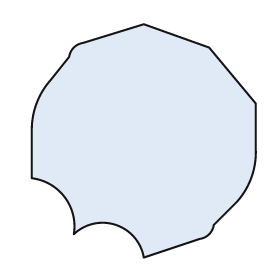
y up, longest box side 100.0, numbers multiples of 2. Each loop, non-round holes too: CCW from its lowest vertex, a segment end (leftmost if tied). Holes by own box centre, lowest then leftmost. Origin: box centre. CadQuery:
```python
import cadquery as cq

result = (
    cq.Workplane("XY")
    .moveTo(0.0, -50.0)
    .lineTo(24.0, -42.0)
    .threePointArc((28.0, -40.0), (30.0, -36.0))
    .lineTo(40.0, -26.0)
    .threePointArc((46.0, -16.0), (48.0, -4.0))
    .lineTo(48.0, 16.0)
    .lineTo(28.0, 40.0)
    .lineTo(0.0, 50.0)
    .lineTo(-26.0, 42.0)
    .threePointArc((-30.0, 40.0), (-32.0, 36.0))
    .lineTo(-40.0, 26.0)
    .threePointArc((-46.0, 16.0), (-48.0, 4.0))
    .lineTo(-48.0, -16.0)
    .threePointArc((-34.0, -24.0), (-30.0, -40.0))
    .threePointArc((-12.0, -36.0), (0.0, -50.0))
    .close()
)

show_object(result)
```